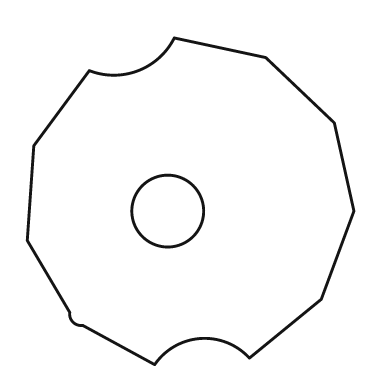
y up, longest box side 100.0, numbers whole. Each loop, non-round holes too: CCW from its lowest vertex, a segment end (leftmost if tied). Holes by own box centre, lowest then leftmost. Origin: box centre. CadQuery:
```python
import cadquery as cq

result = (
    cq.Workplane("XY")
    .moveTo(-11.0, -50.0)
    .threePointArc((3.0, -42.0), (18.0, -48.0))
    .lineTo(40.0, -30.0)
    .lineTo(50.0, -3.0)
    .lineTo(44.0, 24.0)
    .lineTo(23.0, 44.0)
    .lineTo(-5.0, 50.0)
    .threePointArc((-16.0, 40.0), (-31.0, 40.0))
    .lineTo(-48.0, 17.0)
    .lineTo(-50.0, -12.0)
    .lineTo(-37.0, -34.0)
    .threePointArc((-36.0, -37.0), (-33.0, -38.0))
    .close()
    .moveTo(-7.0, -3.0)
    .circle(11.0)
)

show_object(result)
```